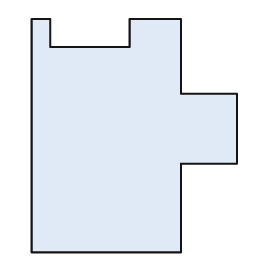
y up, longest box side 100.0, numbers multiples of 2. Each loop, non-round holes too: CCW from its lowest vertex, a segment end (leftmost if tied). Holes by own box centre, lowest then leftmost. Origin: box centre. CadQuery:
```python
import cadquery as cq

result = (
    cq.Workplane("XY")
    .moveTo(-44.0, -50.0)
    .lineTo(20.0, -50.0)
    .lineTo(20.0, -12.0)
    .lineTo(44.0, -12.0)
    .lineTo(44.0, 18.0)
    .lineTo(20.0, 18.0)
    .lineTo(20.0, 50.0)
    .lineTo(-2.0, 50.0)
    .lineTo(-2.0, 38.0)
    .lineTo(-36.0, 38.0)
    .lineTo(-36.0, 50.0)
    .lineTo(-44.0, 50.0)
    .close()
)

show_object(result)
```